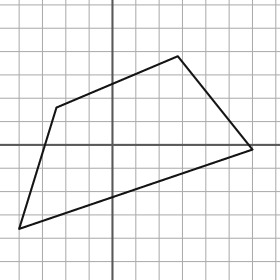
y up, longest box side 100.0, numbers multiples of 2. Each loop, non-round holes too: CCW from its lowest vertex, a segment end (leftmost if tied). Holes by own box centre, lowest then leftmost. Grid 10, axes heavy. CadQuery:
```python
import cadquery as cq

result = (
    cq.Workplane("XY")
    .moveTo(-40.0, -36.0)
    .lineTo(60.0, -2.0)
    .lineTo(28.0, 38.0)
    .lineTo(-24.0, 16.0)
    .close()
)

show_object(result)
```